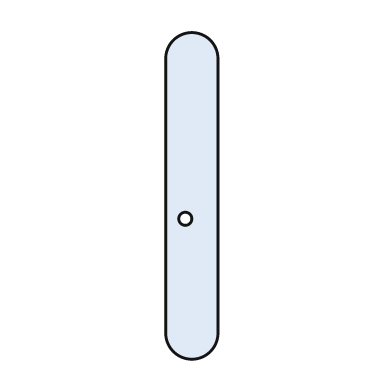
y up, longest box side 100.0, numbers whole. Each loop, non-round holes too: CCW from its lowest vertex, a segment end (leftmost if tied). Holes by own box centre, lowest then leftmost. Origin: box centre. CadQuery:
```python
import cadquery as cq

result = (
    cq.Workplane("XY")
    .moveTo(-8.0, -42.0)
    .threePointArc((0.0, -50.0), (8.0, -42.0))
    .lineTo(8.0, 42.0)
    .threePointArc((0.0, 50.0), (-8.0, 42.0))
    .close()
    .moveTo(-2.0, -7.0)
    .circle(2.0)
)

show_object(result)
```